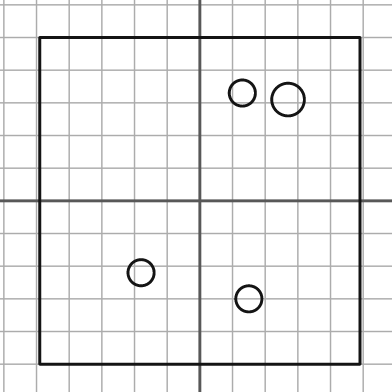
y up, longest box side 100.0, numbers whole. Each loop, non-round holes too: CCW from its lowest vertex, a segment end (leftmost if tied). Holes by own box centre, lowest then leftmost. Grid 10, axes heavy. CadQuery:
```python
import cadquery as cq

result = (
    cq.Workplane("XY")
    .moveTo(-49.0, -50.0)
    .lineTo(49.0, -50.0)
    .lineTo(49.0, 50.0)
    .lineTo(-49.0, 50.0)
    .close()
    .moveTo(15.0, -30.0)
    .circle(4.0)
    .moveTo(-18.0, -22.0)
    .circle(4.0)
    .moveTo(27.0, 31.0)
    .circle(5.0)
    .moveTo(13.0, 33.0)
    .circle(4.0)
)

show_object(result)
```